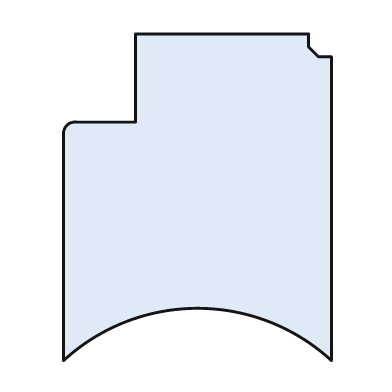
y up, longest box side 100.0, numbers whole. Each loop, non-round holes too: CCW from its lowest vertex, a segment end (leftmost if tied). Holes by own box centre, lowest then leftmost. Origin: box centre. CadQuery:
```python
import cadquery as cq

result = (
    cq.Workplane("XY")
    .moveTo(-41.0, -50.0)
    .threePointArc((0.0, -34.0), (41.0, -50.0))
    .lineTo(41.0, 43.0)
    .lineTo(37.0, 43.0)
    .lineTo(34.0, 46.0)
    .lineTo(34.0, 50.0)
    .lineTo(-19.0, 50.0)
    .lineTo(-19.0, 23.0)
    .lineTo(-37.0, 23.0)
    .threePointArc((-40.0, 22.0), (-41.0, 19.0))
    .close()
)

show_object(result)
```